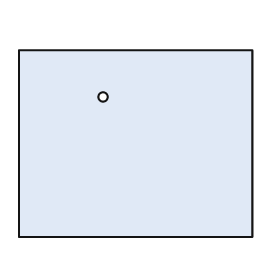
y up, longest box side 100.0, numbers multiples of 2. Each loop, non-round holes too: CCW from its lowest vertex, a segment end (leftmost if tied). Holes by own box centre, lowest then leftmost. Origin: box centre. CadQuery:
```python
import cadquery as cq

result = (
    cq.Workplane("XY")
    .moveTo(-50.0, -40.0)
    .lineTo(50.0, -40.0)
    .lineTo(50.0, 40.0)
    .lineTo(-50.0, 40.0)
    .close()
    .moveTo(-14.0, 20.0)
    .circle(2.0)
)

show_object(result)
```